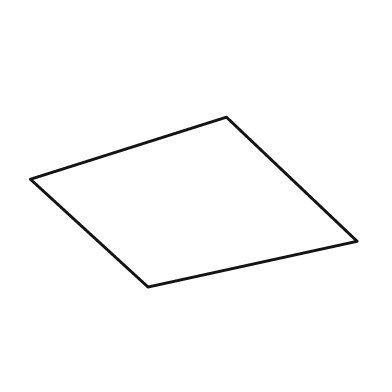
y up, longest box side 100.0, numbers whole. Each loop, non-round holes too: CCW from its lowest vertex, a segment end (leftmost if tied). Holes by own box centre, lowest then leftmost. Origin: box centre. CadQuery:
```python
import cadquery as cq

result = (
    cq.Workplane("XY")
    .moveTo(-14.0, -26.0)
    .lineTo(50.0, -12.0)
    .lineTo(10.0, 26.0)
    .lineTo(-50.0, 7.0)
    .close()
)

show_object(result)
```